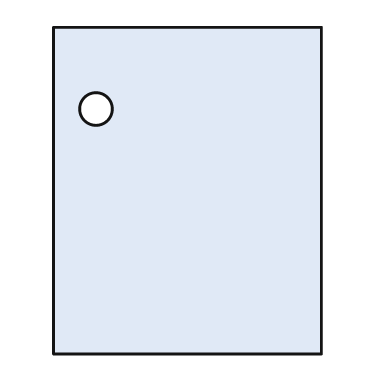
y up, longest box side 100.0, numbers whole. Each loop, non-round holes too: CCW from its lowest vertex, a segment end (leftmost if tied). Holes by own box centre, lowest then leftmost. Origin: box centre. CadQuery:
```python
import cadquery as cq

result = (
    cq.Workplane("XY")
    .moveTo(-41.0, -50.0)
    .lineTo(41.0, -50.0)
    .lineTo(41.0, 50.0)
    .lineTo(-41.0, 50.0)
    .close()
    .moveTo(-28.0, 25.0)
    .circle(5.0)
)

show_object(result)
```